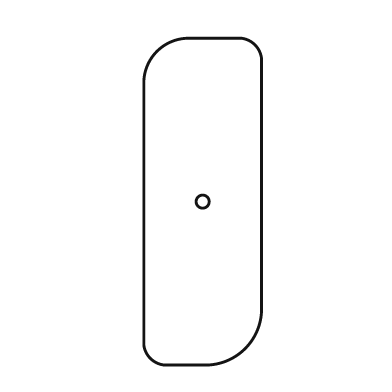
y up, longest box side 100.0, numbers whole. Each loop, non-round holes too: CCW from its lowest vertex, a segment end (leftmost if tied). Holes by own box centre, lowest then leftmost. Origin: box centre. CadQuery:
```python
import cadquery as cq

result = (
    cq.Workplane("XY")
    .moveTo(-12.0, -50.0)
    .lineTo(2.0, -50.0)
    .threePointArc((13.0, -45.0), (18.0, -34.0))
    .lineTo(18.0, 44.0)
    .threePointArc((16.0, 48.0), (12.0, 50.0))
    .lineTo(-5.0, 50.0)
    .threePointArc((-14.0, 46.0), (-18.0, 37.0))
    .lineTo(-18.0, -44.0)
    .threePointArc((-16.0, -48.0), (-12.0, -50.0))
    .close()
    .moveTo(0.0, 0.0)
    .circle(2.0)
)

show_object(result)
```